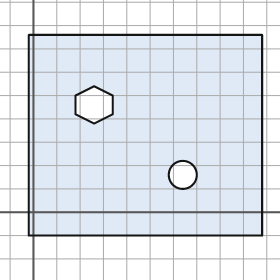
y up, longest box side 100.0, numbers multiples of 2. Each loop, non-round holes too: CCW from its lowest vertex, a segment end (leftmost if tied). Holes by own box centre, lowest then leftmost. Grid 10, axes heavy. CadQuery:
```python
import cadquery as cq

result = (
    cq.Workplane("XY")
    .moveTo(-2.0, -10.0)
    .lineTo(98.0, -10.0)
    .lineTo(98.0, 76.0)
    .lineTo(-2.0, 76.0)
    .close()
    .moveTo(64.0, 16.0)
    .circle(6.0)
    .moveTo(26.0, 38.0)
    .lineTo(34.0, 42.0)
    .lineTo(34.0, 50.0)
    .lineTo(26.0, 54.0)
    .lineTo(18.0, 50.0)
    .lineTo(18.0, 42.0)
    .close()
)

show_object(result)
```